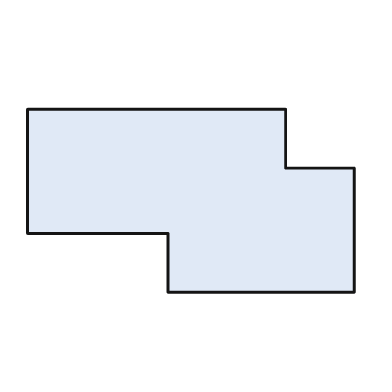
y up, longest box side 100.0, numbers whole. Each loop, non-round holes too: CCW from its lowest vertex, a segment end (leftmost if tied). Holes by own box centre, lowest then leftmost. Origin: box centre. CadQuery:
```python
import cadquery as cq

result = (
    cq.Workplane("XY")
    .moveTo(-7.0, -28.0)
    .lineTo(50.0, -28.0)
    .lineTo(50.0, 10.0)
    .lineTo(29.0, 10.0)
    .lineTo(29.0, 28.0)
    .lineTo(-50.0, 28.0)
    .lineTo(-50.0, -10.0)
    .lineTo(-7.0, -10.0)
    .close()
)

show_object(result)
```